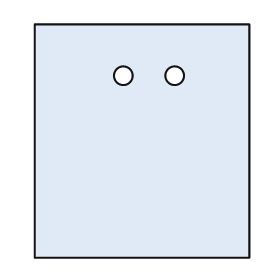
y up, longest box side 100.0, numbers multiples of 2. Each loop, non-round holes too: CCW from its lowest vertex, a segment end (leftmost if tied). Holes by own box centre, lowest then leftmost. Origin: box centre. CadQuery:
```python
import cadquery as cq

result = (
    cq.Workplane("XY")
    .moveTo(-46.0, -50.0)
    .lineTo(46.0, -50.0)
    .lineTo(46.0, 50.0)
    .lineTo(-46.0, 50.0)
    .close()
    .moveTo(-8.0, 28.0)
    .circle(4.0)
    .moveTo(14.0, 28.0)
    .circle(4.0)
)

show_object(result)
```